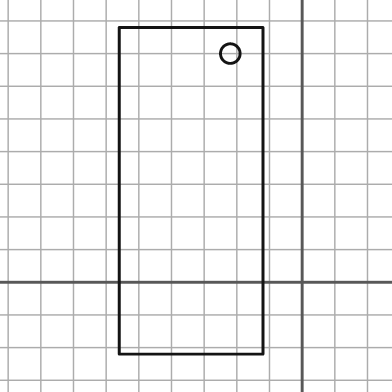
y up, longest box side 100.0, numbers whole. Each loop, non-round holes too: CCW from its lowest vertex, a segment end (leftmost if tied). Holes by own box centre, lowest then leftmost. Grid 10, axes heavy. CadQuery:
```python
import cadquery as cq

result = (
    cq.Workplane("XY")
    .moveTo(-56.0, -22.0)
    .lineTo(-12.0, -22.0)
    .lineTo(-12.0, 78.0)
    .lineTo(-56.0, 78.0)
    .close()
    .moveTo(-22.0, 70.0)
    .circle(3.0)
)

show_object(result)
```